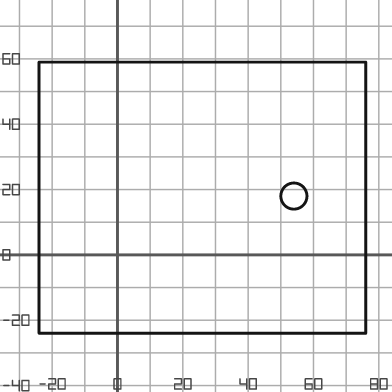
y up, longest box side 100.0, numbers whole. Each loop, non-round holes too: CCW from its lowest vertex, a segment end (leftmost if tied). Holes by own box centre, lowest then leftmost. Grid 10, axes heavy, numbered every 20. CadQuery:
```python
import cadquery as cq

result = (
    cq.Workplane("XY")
    .moveTo(-24.0, -24.0)
    .lineTo(76.0, -24.0)
    .lineTo(76.0, 59.0)
    .lineTo(-24.0, 59.0)
    .close()
    .moveTo(54.0, 18.0)
    .circle(4.0)
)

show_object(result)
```